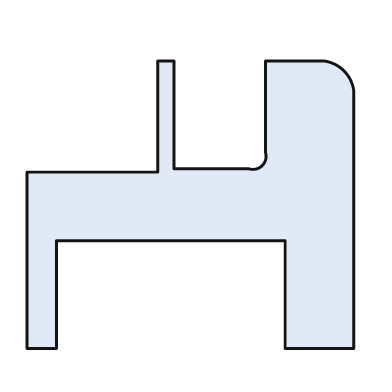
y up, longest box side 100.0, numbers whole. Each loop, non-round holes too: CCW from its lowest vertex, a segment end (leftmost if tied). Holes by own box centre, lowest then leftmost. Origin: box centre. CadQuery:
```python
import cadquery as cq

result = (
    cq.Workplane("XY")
    .moveTo(-50.0, -44.0)
    .lineTo(-41.0, -44.0)
    .lineTo(-41.0, -11.0)
    .lineTo(29.0, -11.0)
    .lineTo(29.0, -44.0)
    .lineTo(50.0, -44.0)
    .lineTo(50.0, 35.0)
    .threePointArc((47.0, 41.0), (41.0, 44.0))
    .lineTo(23.0, 44.0)
    .lineTo(23.0, 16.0)
    .threePointArc((22.0, 12.0), (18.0, 11.0))
    .lineTo(-5.0, 11.0)
    .lineTo(-5.0, 44.0)
    .lineTo(-10.0, 44.0)
    .lineTo(-10.0, 10.0)
    .lineTo(-50.0, 10.0)
    .close()
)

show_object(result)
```